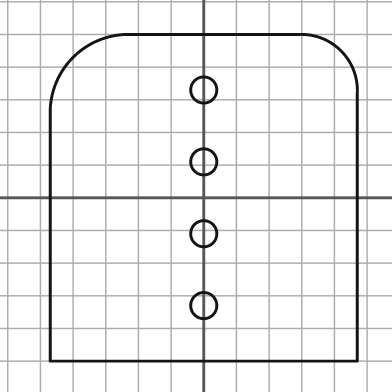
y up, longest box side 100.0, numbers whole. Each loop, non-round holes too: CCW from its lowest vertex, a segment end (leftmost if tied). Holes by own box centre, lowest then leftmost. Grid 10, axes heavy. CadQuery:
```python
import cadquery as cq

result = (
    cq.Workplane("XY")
    .moveTo(-47.0, -50.0)
    .lineTo(47.0, -50.0)
    .lineTo(47.0, 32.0)
    .threePointArc((42.0, 45.0), (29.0, 50.0))
    .lineTo(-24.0, 50.0)
    .threePointArc((-40.0, 43.0), (-47.0, 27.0))
    .close()
    .moveTo(0.0, -33.0)
    .circle(4.0)
    .moveTo(0.0, -11.0)
    .circle(4.0)
    .moveTo(0.0, 11.0)
    .circle(4.0)
    .moveTo(0.0, 33.0)
    .circle(4.0)
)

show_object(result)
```